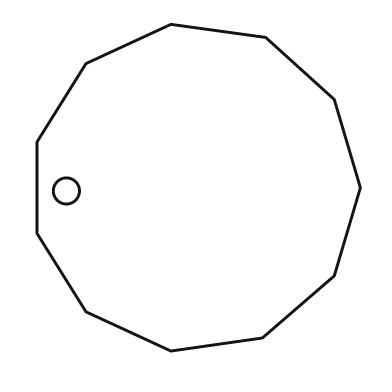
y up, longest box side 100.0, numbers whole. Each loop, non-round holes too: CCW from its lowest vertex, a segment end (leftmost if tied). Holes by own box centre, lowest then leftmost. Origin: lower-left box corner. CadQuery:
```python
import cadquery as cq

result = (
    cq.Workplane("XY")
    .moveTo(41.0, 0.0)
    .lineTo(69.0, 4.0)
    .lineTo(91.0, 23.0)
    .lineTo(99.0, 50.0)
    .lineTo(91.0, 77.0)
    .lineTo(70.0, 96.0)
    .lineTo(41.0, 100.0)
    .lineTo(15.0, 88.0)
    .lineTo(0.0, 64.0)
    .lineTo(0.0, 36.0)
    .lineTo(15.0, 12.0)
    .close()
    .moveTo(9.0, 49.0)
    .circle(4.0)
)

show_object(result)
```